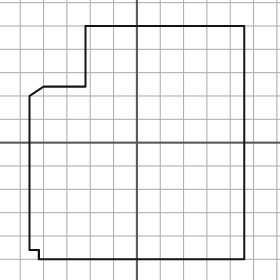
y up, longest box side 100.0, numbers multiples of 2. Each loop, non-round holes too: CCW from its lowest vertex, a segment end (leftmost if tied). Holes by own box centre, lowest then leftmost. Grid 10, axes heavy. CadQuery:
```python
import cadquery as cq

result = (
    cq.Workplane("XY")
    .moveTo(-42.0, -50.0)
    .lineTo(46.0, -50.0)
    .lineTo(46.0, 50.0)
    .lineTo(-22.0, 50.0)
    .lineTo(-22.0, 24.0)
    .lineTo(-40.0, 24.0)
    .lineTo(-46.0, 20.0)
    .lineTo(-46.0, -46.0)
    .lineTo(-42.0, -46.0)
    .close()
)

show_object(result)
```